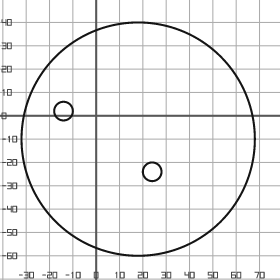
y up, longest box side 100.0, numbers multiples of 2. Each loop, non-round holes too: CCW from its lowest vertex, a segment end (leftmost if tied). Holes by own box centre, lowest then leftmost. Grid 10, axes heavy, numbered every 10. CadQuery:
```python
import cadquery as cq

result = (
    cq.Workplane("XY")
    .moveTo(18.0, -10.0)
    .circle(50.0)
    .moveTo(24.0, -24.0)
    .circle(4.0)
    .moveTo(-14.0, 2.0)
    .circle(4.0)
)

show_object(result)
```